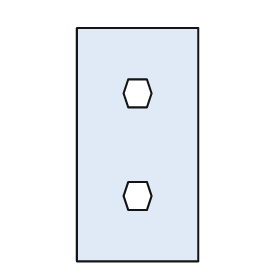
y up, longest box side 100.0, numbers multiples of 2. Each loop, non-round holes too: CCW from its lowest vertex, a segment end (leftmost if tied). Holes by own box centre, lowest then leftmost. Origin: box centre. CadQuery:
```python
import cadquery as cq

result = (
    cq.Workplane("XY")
    .moveTo(-26.0, -50.0)
    .lineTo(26.0, -50.0)
    .lineTo(26.0, 50.0)
    .lineTo(-26.0, 50.0)
    .close()
    .moveTo(-4.0, -28.0)
    .lineTo(4.0, -28.0)
    .lineTo(6.0, -22.0)
    .lineTo(4.0, -16.0)
    .lineTo(-4.0, -16.0)
    .lineTo(-6.0, -22.0)
    .close()
    .moveTo(-4.0, 16.0)
    .lineTo(4.0, 16.0)
    .lineTo(6.0, 22.0)
    .lineTo(4.0, 28.0)
    .lineTo(-4.0, 28.0)
    .lineTo(-6.0, 22.0)
    .close()
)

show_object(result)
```